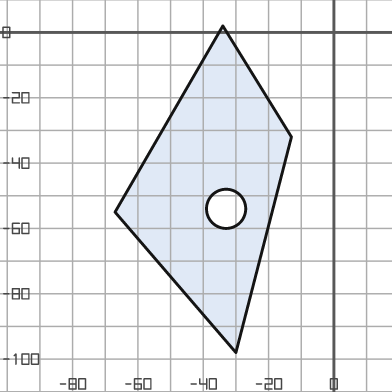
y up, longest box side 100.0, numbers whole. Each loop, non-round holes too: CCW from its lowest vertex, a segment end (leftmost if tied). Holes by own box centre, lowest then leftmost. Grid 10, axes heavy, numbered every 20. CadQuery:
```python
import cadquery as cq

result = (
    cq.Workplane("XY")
    .moveTo(-30.0, -98.0)
    .lineTo(-13.0, -32.0)
    .lineTo(-34.0, 2.0)
    .lineTo(-67.0, -55.0)
    .close()
    .moveTo(-33.0, -54.0)
    .circle(6.0)
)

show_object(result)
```